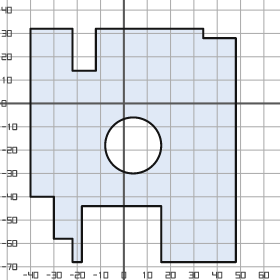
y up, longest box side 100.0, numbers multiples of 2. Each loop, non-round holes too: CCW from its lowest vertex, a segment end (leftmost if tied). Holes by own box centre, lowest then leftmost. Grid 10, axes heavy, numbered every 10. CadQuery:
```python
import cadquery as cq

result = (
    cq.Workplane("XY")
    .moveTo(-22.0, -68.0)
    .lineTo(-18.0, -68.0)
    .lineTo(-18.0, -44.0)
    .lineTo(16.0, -44.0)
    .lineTo(16.0, -68.0)
    .lineTo(48.0, -68.0)
    .lineTo(48.0, 28.0)
    .lineTo(34.0, 28.0)
    .lineTo(34.0, 32.0)
    .lineTo(-12.0, 32.0)
    .lineTo(-12.0, 14.0)
    .lineTo(-22.0, 14.0)
    .lineTo(-22.0, 32.0)
    .lineTo(-40.0, 32.0)
    .lineTo(-40.0, -40.0)
    .lineTo(-30.0, -40.0)
    .lineTo(-30.0, -58.0)
    .lineTo(-22.0, -58.0)
    .close()
    .moveTo(4.0, -18.0)
    .circle(12.0)
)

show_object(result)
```